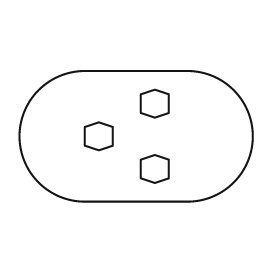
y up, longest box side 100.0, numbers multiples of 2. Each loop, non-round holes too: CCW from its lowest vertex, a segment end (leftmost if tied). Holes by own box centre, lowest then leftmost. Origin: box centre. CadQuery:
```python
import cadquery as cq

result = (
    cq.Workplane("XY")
    .moveTo(-22.0, -28.0)
    .lineTo(22.0, -28.0)
    .threePointArc((50.0, 0.0), (22.0, 28.0))
    .lineTo(-22.0, 28.0)
    .threePointArc((-50.0, 0.0), (-22.0, -28.0))
    .close()
    .moveTo(8.0, -20.0)
    .lineTo(14.0, -18.0)
    .lineTo(14.0, -10.0)
    .lineTo(8.0, -8.0)
    .lineTo(2.0, -10.0)
    .lineTo(2.0, -18.0)
    .close()
    .moveTo(-16.0, -6.0)
    .lineTo(-10.0, -4.0)
    .lineTo(-10.0, 4.0)
    .lineTo(-16.0, 6.0)
    .lineTo(-22.0, 4.0)
    .lineTo(-22.0, -4.0)
    .close()
    .moveTo(8.0, 8.0)
    .lineTo(14.0, 10.0)
    .lineTo(14.0, 18.0)
    .lineTo(8.0, 20.0)
    .lineTo(2.0, 18.0)
    .lineTo(2.0, 10.0)
    .close()
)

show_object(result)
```